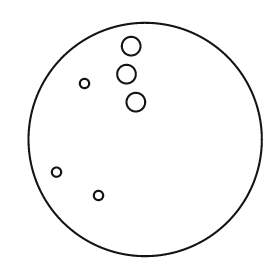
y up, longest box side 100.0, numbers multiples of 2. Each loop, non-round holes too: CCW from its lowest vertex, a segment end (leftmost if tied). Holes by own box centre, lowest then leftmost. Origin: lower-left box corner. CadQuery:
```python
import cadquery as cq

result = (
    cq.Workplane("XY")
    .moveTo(50.0, 50.0)
    .circle(50.0)
    .moveTo(30.0, 26.0)
    .circle(2.0)
    .moveTo(12.0, 36.0)
    .circle(2.0)
    .moveTo(46.0, 66.0)
    .circle(4.0)
    .moveTo(24.0, 74.0)
    .circle(2.0)
    .moveTo(42.0, 78.0)
    .circle(4.0)
    .moveTo(44.0, 90.0)
    .circle(4.0)
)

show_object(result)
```